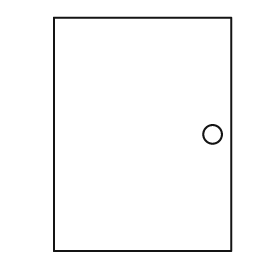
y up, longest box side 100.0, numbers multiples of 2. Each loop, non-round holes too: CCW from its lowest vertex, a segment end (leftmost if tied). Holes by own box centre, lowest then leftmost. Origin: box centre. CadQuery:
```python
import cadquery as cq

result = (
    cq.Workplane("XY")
    .moveTo(-38.0, -50.0)
    .lineTo(38.0, -50.0)
    .lineTo(38.0, 50.0)
    .lineTo(-38.0, 50.0)
    .close()
    .moveTo(30.0, 0.0)
    .circle(4.0)
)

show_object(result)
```